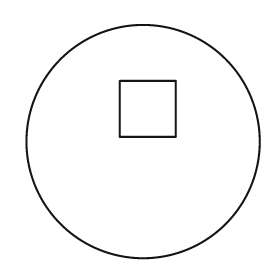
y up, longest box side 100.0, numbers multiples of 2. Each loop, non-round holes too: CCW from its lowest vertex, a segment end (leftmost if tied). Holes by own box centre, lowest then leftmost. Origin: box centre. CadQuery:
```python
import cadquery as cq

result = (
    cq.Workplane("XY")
    .moveTo(0.0, 0.0)
    .circle(50.0)
    .moveTo(-10.0, 2.0)
    .lineTo(14.0, 2.0)
    .lineTo(14.0, 26.0)
    .lineTo(-10.0, 26.0)
    .close()
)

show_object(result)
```